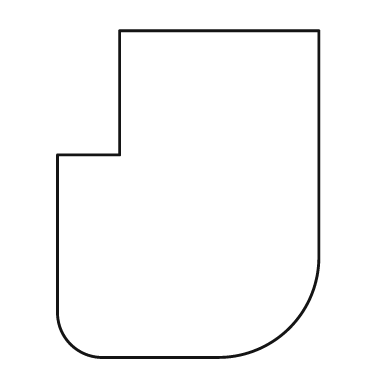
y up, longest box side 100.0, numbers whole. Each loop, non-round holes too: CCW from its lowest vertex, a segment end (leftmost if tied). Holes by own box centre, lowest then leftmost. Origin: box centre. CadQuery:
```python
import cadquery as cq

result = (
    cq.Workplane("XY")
    .moveTo(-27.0, -50.0)
    .lineTo(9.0, -50.0)
    .threePointArc((31.0, -41.0), (40.0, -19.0))
    .lineTo(40.0, 50.0)
    .lineTo(-21.0, 50.0)
    .lineTo(-21.0, 12.0)
    .lineTo(-40.0, 12.0)
    .lineTo(-40.0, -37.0)
    .threePointArc((-36.0, -46.0), (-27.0, -50.0))
    .close()
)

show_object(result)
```